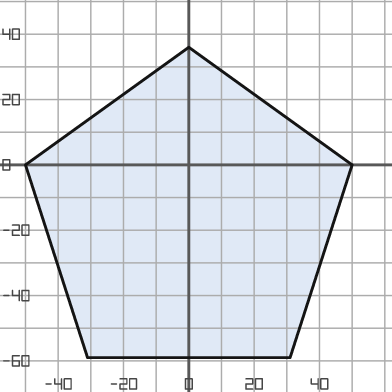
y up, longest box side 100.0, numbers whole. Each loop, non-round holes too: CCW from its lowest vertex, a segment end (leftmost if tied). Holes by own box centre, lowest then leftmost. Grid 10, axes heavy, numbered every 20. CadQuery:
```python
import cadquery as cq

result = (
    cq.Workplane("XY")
    .moveTo(-31.0, -59.0)
    .lineTo(31.0, -59.0)
    .lineTo(50.0, 0.0)
    .lineTo(0.0, 36.0)
    .lineTo(-50.0, 0.0)
    .close()
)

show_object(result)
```